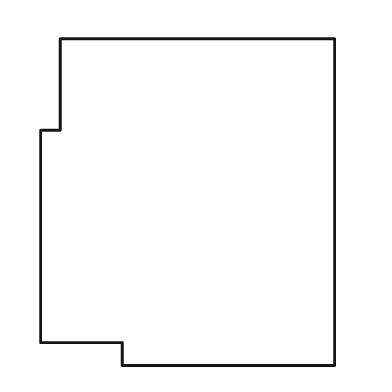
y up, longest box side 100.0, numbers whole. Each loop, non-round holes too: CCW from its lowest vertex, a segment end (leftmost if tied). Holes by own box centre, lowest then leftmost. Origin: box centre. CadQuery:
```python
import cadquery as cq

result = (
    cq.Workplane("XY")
    .moveTo(-20.0, -50.0)
    .lineTo(45.0, -50.0)
    .lineTo(45.0, 50.0)
    .lineTo(-39.0, 50.0)
    .lineTo(-39.0, 22.0)
    .lineTo(-45.0, 22.0)
    .lineTo(-45.0, -43.0)
    .lineTo(-20.0, -43.0)
    .close()
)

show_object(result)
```